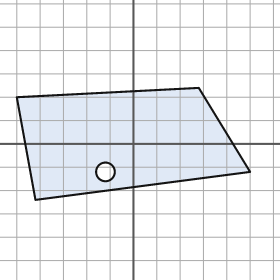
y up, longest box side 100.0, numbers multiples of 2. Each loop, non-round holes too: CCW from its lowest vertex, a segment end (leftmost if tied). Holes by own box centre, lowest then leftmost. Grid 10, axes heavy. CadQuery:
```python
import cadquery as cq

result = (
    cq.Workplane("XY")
    .moveTo(-42.0, -24.0)
    .lineTo(50.0, -12.0)
    .lineTo(28.0, 24.0)
    .lineTo(-50.0, 20.0)
    .close()
    .moveTo(-12.0, -12.0)
    .circle(4.0)
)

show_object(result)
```